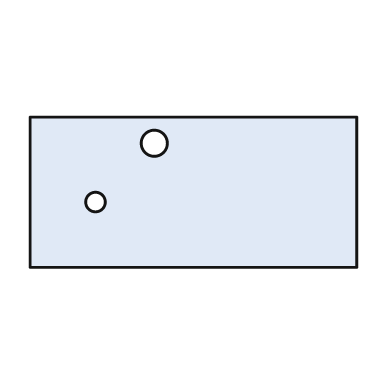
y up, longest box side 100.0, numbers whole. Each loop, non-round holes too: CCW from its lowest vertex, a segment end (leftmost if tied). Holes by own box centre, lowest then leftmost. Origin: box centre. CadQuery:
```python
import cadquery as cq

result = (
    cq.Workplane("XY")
    .moveTo(-50.0, -23.0)
    .lineTo(50.0, -23.0)
    .lineTo(50.0, 23.0)
    .lineTo(-50.0, 23.0)
    .close()
    .moveTo(-30.0, -3.0)
    .circle(3.0)
    .moveTo(-12.0, 15.0)
    .circle(4.0)
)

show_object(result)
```